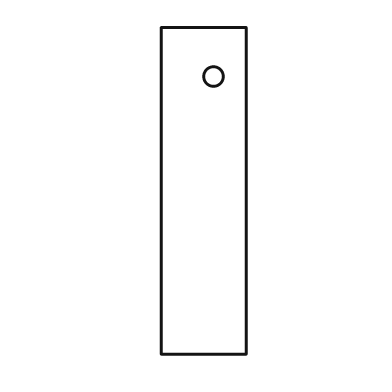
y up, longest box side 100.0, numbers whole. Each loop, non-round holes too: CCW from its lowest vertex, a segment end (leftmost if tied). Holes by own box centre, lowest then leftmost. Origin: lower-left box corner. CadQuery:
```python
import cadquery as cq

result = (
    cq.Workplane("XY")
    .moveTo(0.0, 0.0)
    .lineTo(26.0, 0.0)
    .lineTo(26.0, 100.0)
    .lineTo(0.0, 100.0)
    .close()
    .moveTo(16.0, 85.0)
    .circle(3.0)
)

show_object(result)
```